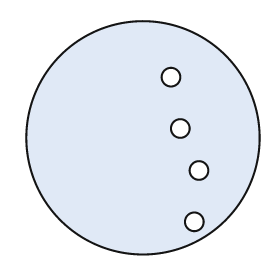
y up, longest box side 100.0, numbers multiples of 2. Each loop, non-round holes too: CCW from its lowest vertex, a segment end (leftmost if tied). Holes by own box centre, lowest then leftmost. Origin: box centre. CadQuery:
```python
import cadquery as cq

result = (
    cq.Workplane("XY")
    .moveTo(0.0, 0.0)
    .circle(50.0)
    .moveTo(22.0, -36.0)
    .circle(4.0)
    .moveTo(24.0, -14.0)
    .circle(4.0)
    .moveTo(16.0, 4.0)
    .circle(4.0)
    .moveTo(12.0, 26.0)
    .circle(4.0)
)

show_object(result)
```